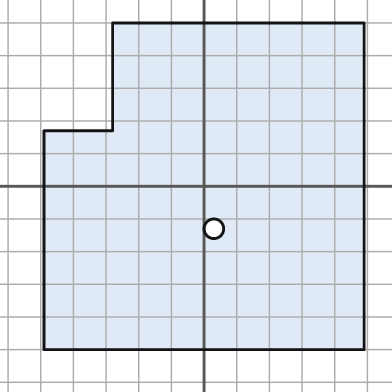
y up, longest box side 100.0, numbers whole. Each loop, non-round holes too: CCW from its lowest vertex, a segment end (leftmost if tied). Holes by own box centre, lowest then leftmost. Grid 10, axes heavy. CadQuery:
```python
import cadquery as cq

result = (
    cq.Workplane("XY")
    .moveTo(-49.0, -50.0)
    .lineTo(49.0, -50.0)
    .lineTo(49.0, 50.0)
    .lineTo(-28.0, 50.0)
    .lineTo(-28.0, 17.0)
    .lineTo(-49.0, 17.0)
    .close()
    .moveTo(3.0, -13.0)
    .circle(3.0)
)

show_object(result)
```